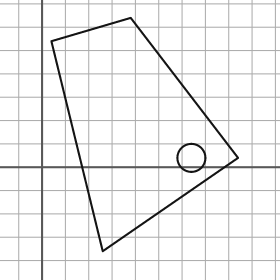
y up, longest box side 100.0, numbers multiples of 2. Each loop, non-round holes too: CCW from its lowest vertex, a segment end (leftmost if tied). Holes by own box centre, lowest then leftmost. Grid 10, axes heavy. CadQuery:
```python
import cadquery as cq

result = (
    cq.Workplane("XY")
    .moveTo(26.0, -36.0)
    .lineTo(84.0, 4.0)
    .lineTo(38.0, 64.0)
    .lineTo(4.0, 54.0)
    .close()
    .moveTo(64.0, 4.0)
    .circle(6.0)
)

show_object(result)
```